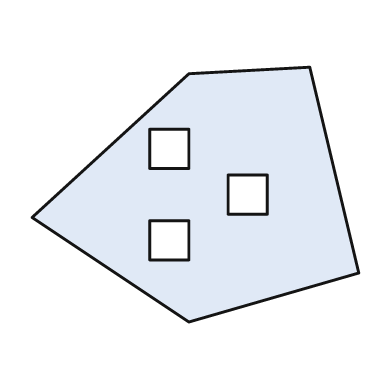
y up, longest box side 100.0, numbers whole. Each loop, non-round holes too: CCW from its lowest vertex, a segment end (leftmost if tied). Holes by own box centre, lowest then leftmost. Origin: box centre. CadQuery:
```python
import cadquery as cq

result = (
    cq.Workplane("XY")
    .moveTo(-2.0, -39.0)
    .lineTo(50.0, -24.0)
    .lineTo(35.0, 39.0)
    .lineTo(-2.0, 37.0)
    .lineTo(-50.0, -7.0)
    .close()
    .moveTo(-14.0, -20.0)
    .lineTo(-2.0, -20.0)
    .lineTo(-2.0, -8.0)
    .lineTo(-14.0, -8.0)
    .close()
    .moveTo(10.0, -6.0)
    .lineTo(22.0, -6.0)
    .lineTo(22.0, 6.0)
    .lineTo(10.0, 6.0)
    .close()
    .moveTo(-14.0, 8.0)
    .lineTo(-2.0, 8.0)
    .lineTo(-2.0, 20.0)
    .lineTo(-14.0, 20.0)
    .close()
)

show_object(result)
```